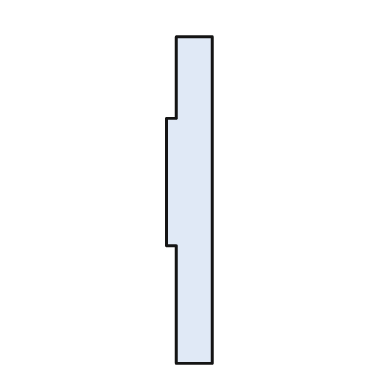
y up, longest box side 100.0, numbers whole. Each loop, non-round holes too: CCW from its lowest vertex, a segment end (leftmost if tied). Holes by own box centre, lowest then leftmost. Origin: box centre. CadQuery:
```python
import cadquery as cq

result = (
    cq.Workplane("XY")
    .moveTo(-4.0, -50.0)
    .lineTo(7.0, -50.0)
    .lineTo(7.0, 50.0)
    .lineTo(-4.0, 50.0)
    .lineTo(-4.0, 25.0)
    .lineTo(-7.0, 25.0)
    .lineTo(-7.0, -14.0)
    .lineTo(-4.0, -14.0)
    .close()
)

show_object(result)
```